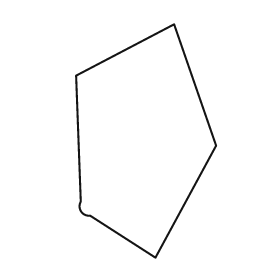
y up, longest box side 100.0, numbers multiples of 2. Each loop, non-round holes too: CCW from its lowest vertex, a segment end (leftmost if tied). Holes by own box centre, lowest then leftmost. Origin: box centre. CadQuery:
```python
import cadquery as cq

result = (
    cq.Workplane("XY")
    .moveTo(4.0, -50.0)
    .lineTo(30.0, -2.0)
    .lineTo(12.0, 50.0)
    .lineTo(-30.0, 28.0)
    .lineTo(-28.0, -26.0)
    .threePointArc((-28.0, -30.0), (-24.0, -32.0))
    .close()
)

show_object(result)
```